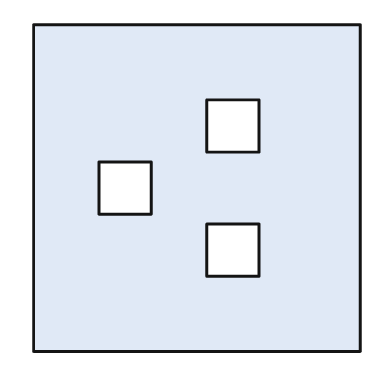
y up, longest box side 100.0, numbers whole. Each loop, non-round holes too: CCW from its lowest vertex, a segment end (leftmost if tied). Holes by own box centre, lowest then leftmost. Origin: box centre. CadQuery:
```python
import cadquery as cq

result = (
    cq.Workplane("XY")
    .moveTo(-50.0, -50.0)
    .lineTo(50.0, -50.0)
    .lineTo(50.0, 50.0)
    .lineTo(-50.0, 50.0)
    .close()
    .moveTo(3.0, -27.0)
    .lineTo(19.0, -27.0)
    .lineTo(19.0, -11.0)
    .lineTo(3.0, -11.0)
    .close()
    .moveTo(-30.0, -8.0)
    .lineTo(-14.0, -8.0)
    .lineTo(-14.0, 8.0)
    .lineTo(-30.0, 8.0)
    .close()
    .moveTo(3.0, 11.0)
    .lineTo(19.0, 11.0)
    .lineTo(19.0, 27.0)
    .lineTo(3.0, 27.0)
    .close()
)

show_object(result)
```